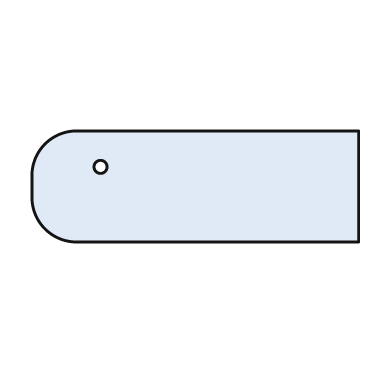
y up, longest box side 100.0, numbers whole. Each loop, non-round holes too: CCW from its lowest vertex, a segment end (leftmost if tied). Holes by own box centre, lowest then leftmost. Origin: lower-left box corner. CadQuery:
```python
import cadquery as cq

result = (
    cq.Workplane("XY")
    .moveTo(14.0, 0.0)
    .lineTo(100.0, 0.0)
    .lineTo(100.0, 34.0)
    .lineTo(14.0, 34.0)
    .threePointArc((4.0, 30.0), (0.0, 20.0))
    .lineTo(0.0, 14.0)
    .threePointArc((4.0, 4.0), (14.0, 0.0))
    .close()
    .moveTo(21.0, 23.0)
    .circle(2.0)
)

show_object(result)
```